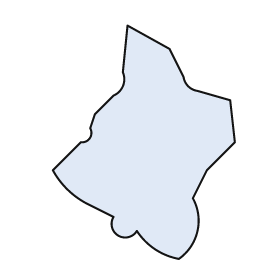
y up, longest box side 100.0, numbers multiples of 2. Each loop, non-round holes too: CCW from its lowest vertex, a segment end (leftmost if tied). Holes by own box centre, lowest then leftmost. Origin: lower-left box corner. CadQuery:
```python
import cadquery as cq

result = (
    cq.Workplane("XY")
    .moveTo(54.0, 0.0)
    .threePointArc((62.0, 12.0), (60.0, 26.0))
    .lineTo(66.0, 38.0)
    .lineTo(78.0, 50.0)
    .lineTo(76.0, 68.0)
    .lineTo(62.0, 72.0)
    .threePointArc((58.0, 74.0), (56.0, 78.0))
    .lineTo(50.0, 90.0)
    .lineTo(32.0, 100.0)
    .lineTo(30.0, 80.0)
    .threePointArc((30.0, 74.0), (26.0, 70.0))
    .lineTo(18.0, 62.0)
    .lineTo(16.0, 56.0)
    .threePointArc((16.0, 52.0), (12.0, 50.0))
    .lineTo(0.0, 38.0)
    .threePointArc((6.0, 30.0), (14.0, 24.0))
    .lineTo(26.0, 18.0)
    .threePointArc((28.0, 10.0), (36.0, 12.0))
    .threePointArc((44.0, 4.0), (54.0, 0.0))
    .close()
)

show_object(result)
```